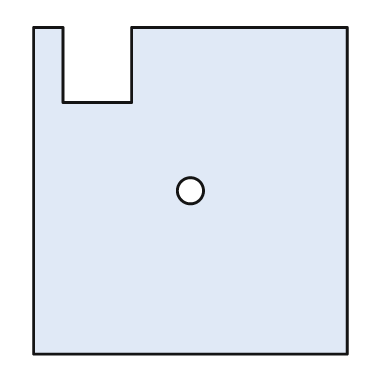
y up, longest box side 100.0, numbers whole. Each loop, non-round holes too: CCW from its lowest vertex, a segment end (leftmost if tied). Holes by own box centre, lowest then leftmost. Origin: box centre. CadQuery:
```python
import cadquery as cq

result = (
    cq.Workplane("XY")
    .moveTo(-48.0, -50.0)
    .lineTo(48.0, -50.0)
    .lineTo(48.0, 50.0)
    .lineTo(-18.0, 50.0)
    .lineTo(-18.0, 27.0)
    .lineTo(-39.0, 27.0)
    .lineTo(-39.0, 50.0)
    .lineTo(-48.0, 50.0)
    .close()
    .moveTo(0.0, 0.0)
    .circle(4.0)
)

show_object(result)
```